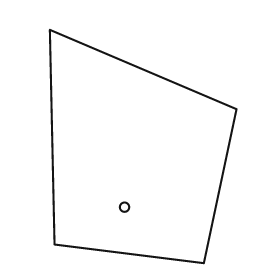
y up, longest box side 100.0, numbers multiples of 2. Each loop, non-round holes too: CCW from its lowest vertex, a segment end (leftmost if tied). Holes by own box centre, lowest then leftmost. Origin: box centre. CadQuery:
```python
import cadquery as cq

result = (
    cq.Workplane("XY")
    .moveTo(26.0, -50.0)
    .lineTo(40.0, 16.0)
    .lineTo(-40.0, 50.0)
    .lineTo(-38.0, -42.0)
    .close()
    .moveTo(-8.0, -26.0)
    .circle(2.0)
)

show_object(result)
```